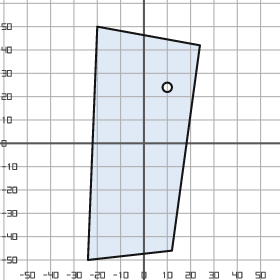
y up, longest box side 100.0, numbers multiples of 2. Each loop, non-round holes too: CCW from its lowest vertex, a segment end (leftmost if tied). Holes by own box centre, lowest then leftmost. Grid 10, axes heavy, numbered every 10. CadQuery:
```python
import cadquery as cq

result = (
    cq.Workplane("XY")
    .moveTo(-24.0, -50.0)
    .lineTo(12.0, -46.0)
    .lineTo(24.0, 42.0)
    .lineTo(-20.0, 50.0)
    .close()
    .moveTo(10.0, 24.0)
    .circle(2.0)
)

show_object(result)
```